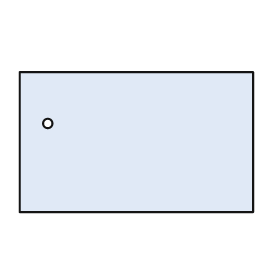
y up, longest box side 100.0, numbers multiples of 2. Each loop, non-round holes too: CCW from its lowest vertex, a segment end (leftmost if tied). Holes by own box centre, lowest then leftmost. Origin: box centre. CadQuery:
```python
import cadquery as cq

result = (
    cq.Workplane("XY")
    .moveTo(-50.0, -30.0)
    .lineTo(50.0, -30.0)
    .lineTo(50.0, 30.0)
    .lineTo(-50.0, 30.0)
    .close()
    .moveTo(-38.0, 8.0)
    .circle(2.0)
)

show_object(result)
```